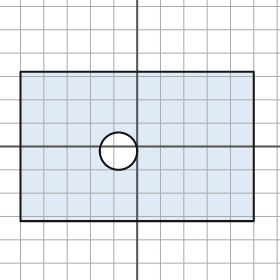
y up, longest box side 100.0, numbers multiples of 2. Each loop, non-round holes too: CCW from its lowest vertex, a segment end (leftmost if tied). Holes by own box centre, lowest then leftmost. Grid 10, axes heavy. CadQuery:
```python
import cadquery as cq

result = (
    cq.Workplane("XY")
    .moveTo(-50.0, -32.0)
    .lineTo(50.0, -32.0)
    .lineTo(50.0, 32.0)
    .lineTo(-50.0, 32.0)
    .close()
    .moveTo(-8.0, -2.0)
    .circle(8.0)
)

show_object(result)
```